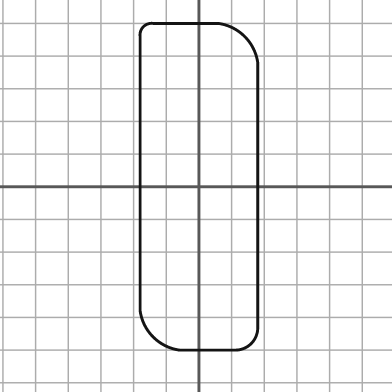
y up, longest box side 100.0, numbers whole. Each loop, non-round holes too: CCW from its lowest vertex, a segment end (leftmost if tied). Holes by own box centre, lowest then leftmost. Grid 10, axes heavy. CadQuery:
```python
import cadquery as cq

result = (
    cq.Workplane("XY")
    .moveTo(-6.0, -50.0)
    .lineTo(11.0, -50.0)
    .threePointArc((16.0, -48.0), (18.0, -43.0))
    .lineTo(18.0, 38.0)
    .threePointArc((14.0, 46.0), (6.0, 50.0))
    .lineTo(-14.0, 50.0)
    .threePointArc((-17.0, 49.0), (-18.0, 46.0))
    .lineTo(-18.0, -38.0)
    .threePointArc((-14.0, -46.0), (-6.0, -50.0))
    .close()
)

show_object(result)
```